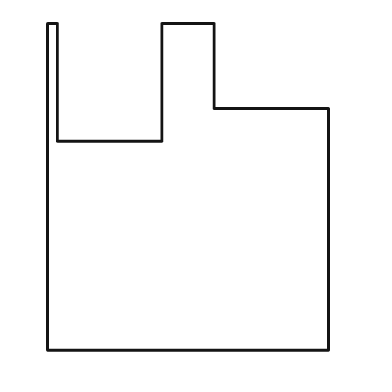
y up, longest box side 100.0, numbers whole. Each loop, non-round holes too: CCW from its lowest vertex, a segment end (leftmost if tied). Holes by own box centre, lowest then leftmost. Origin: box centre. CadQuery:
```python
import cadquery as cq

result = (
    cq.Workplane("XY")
    .moveTo(-43.0, -50.0)
    .lineTo(43.0, -50.0)
    .lineTo(43.0, 24.0)
    .lineTo(8.0, 24.0)
    .lineTo(8.0, 50.0)
    .lineTo(-8.0, 50.0)
    .lineTo(-8.0, 14.0)
    .lineTo(-40.0, 14.0)
    .lineTo(-40.0, 50.0)
    .lineTo(-43.0, 50.0)
    .close()
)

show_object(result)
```